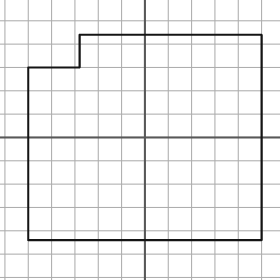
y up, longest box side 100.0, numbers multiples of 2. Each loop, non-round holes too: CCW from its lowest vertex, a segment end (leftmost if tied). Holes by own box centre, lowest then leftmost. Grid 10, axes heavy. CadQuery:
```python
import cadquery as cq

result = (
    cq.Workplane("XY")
    .moveTo(-50.0, -44.0)
    .lineTo(50.0, -44.0)
    .lineTo(50.0, 44.0)
    .lineTo(-28.0, 44.0)
    .lineTo(-28.0, 30.0)
    .lineTo(-50.0, 30.0)
    .close()
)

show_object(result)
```